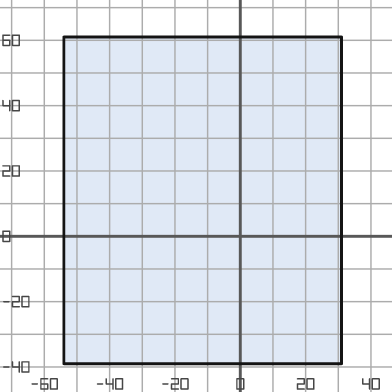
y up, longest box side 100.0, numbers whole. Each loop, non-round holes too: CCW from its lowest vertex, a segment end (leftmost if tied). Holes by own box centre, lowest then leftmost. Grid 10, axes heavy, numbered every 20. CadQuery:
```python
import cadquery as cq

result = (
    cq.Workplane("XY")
    .moveTo(-54.0, -39.0)
    .lineTo(31.0, -39.0)
    .lineTo(31.0, 61.0)
    .lineTo(-54.0, 61.0)
    .close()
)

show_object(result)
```